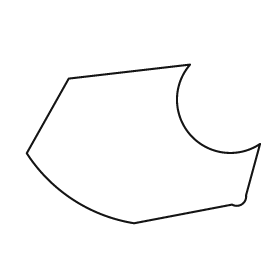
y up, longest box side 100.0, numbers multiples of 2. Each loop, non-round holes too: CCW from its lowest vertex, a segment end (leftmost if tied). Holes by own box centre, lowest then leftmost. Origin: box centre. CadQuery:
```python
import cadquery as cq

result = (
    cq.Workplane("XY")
    .moveTo(-4.0, -34.0)
    .lineTo(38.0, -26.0)
    .threePointArc((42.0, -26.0), (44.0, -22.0))
    .lineTo(50.0, 0.0)
    .threePointArc((20.0, 4.0), (20.0, 34.0))
    .lineTo(-32.0, 28.0)
    .lineTo(-50.0, -4.0)
    .threePointArc((-30.0, -24.0), (-4.0, -34.0))
    .close()
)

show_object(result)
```